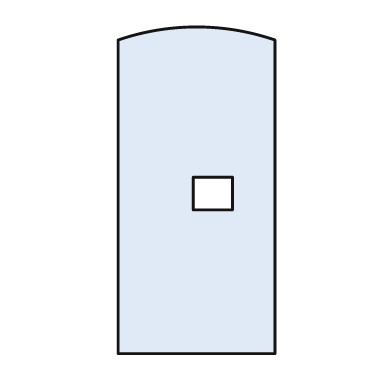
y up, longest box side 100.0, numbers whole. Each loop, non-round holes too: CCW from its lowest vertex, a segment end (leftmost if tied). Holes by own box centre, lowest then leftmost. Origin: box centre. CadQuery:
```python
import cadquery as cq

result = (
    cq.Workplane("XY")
    .moveTo(-24.0, -50.0)
    .lineTo(24.0, -50.0)
    .lineTo(24.0, 46.0)
    .threePointArc((0.0, 50.0), (-24.0, 46.0))
    .close()
    .moveTo(-1.0, -6.0)
    .lineTo(11.0, -6.0)
    .lineTo(11.0, 4.0)
    .lineTo(-1.0, 4.0)
    .close()
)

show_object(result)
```